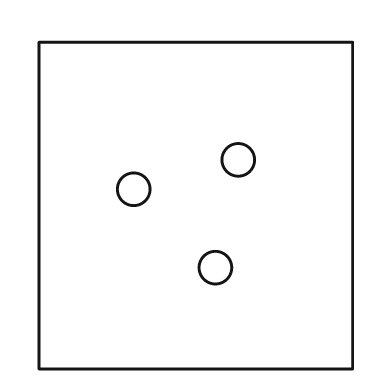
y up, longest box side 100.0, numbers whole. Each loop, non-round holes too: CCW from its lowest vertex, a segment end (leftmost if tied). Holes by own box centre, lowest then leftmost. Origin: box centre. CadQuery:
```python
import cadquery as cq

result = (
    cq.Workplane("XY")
    .moveTo(-48.0, -50.0)
    .lineTo(48.0, -50.0)
    .lineTo(48.0, 50.0)
    .lineTo(-48.0, 50.0)
    .close()
    .moveTo(6.0, -19.0)
    .circle(5.0)
    .moveTo(-19.0, 5.0)
    .circle(5.0)
    .moveTo(13.0, 14.0)
    .circle(5.0)
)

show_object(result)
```